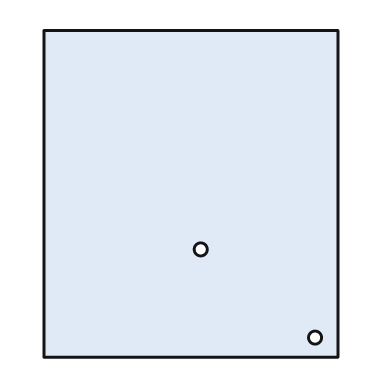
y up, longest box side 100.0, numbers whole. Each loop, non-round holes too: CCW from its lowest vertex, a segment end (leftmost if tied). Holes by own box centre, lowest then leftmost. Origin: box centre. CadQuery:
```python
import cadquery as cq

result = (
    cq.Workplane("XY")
    .moveTo(-45.0, -50.0)
    .lineTo(45.0, -50.0)
    .lineTo(45.0, 50.0)
    .lineTo(-45.0, 50.0)
    .close()
    .moveTo(38.0, -44.0)
    .circle(2.0)
    .moveTo(3.0, -17.0)
    .circle(2.0)
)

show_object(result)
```